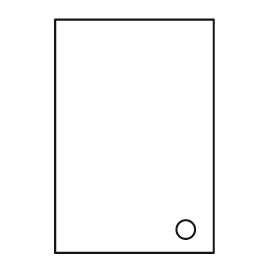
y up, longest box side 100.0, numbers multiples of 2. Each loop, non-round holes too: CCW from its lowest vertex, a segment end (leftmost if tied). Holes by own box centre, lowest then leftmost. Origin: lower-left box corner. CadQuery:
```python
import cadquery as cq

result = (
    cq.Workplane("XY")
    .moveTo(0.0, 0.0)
    .lineTo(68.0, 0.0)
    .lineTo(68.0, 100.0)
    .lineTo(0.0, 100.0)
    .close()
    .moveTo(56.0, 10.0)
    .circle(4.0)
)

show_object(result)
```